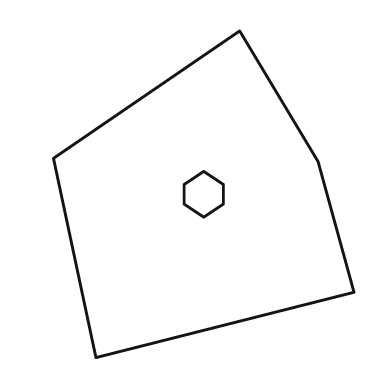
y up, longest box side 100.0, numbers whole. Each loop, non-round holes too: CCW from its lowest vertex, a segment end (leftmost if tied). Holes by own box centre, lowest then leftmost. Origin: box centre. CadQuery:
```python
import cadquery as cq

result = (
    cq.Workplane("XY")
    .moveTo(-33.0, -50.0)
    .lineTo(46.0, -30.0)
    .lineTo(35.0, 10.0)
    .lineTo(11.0, 50.0)
    .lineTo(-46.0, 11.0)
    .close()
    .moveTo(0.0, -7.0)
    .lineTo(6.0, -3.0)
    .lineTo(6.0, 3.0)
    .lineTo(0.0, 7.0)
    .lineTo(-6.0, 3.0)
    .lineTo(-6.0, -3.0)
    .close()
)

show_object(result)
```